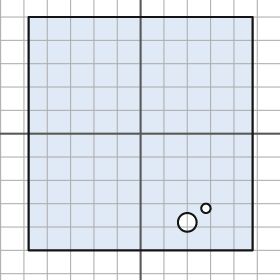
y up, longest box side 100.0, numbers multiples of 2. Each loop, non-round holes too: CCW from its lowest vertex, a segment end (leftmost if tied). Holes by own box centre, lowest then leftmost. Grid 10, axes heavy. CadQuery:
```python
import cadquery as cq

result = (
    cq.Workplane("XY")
    .moveTo(-48.0, -50.0)
    .lineTo(48.0, -50.0)
    .lineTo(48.0, 50.0)
    .lineTo(-48.0, 50.0)
    .close()
    .moveTo(20.0, -38.0)
    .circle(4.0)
    .moveTo(28.0, -32.0)
    .circle(2.0)
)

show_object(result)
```